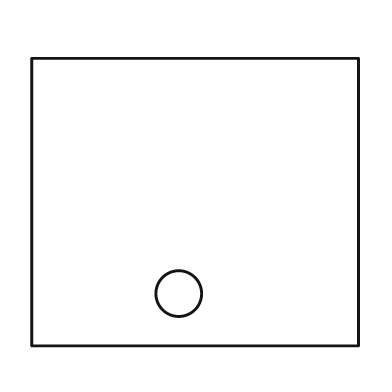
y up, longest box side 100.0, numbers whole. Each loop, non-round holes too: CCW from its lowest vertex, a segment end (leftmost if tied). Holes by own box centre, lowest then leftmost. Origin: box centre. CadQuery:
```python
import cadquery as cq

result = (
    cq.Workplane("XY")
    .moveTo(-50.0, -44.0)
    .lineTo(50.0, -44.0)
    .lineTo(50.0, 44.0)
    .lineTo(-50.0, 44.0)
    .close()
    .moveTo(-5.0, -28.0)
    .circle(7.0)
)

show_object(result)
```